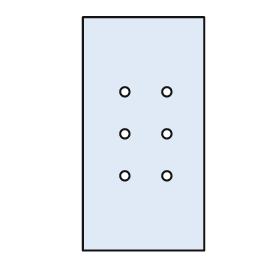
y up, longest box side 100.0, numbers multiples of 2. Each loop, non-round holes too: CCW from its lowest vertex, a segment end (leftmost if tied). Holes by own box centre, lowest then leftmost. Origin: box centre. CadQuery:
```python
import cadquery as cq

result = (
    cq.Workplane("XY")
    .moveTo(-26.0, -50.0)
    .lineTo(26.0, -50.0)
    .lineTo(26.0, 50.0)
    .lineTo(-26.0, 50.0)
    .close()
    .moveTo(-8.0, -18.0)
    .circle(2.0)
    .moveTo(10.0, -18.0)
    .circle(2.0)
    .moveTo(-8.0, 0.0)
    .circle(2.0)
    .moveTo(10.0, 0.0)
    .circle(2.0)
    .moveTo(-8.0, 18.0)
    .circle(2.0)
    .moveTo(10.0, 18.0)
    .circle(2.0)
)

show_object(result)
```